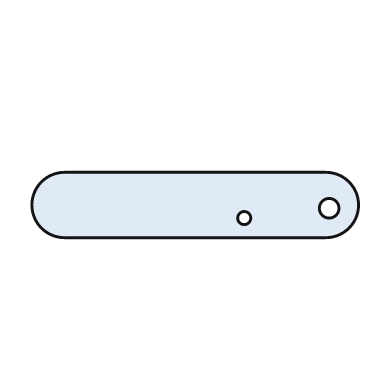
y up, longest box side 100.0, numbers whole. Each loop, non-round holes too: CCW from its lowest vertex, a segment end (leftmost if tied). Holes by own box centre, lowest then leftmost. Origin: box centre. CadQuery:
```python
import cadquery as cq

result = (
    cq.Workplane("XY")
    .moveTo(-40.0, -10.0)
    .lineTo(40.0, -10.0)
    .threePointArc((50.0, 0.0), (40.0, 10.0))
    .lineTo(-40.0, 10.0)
    .threePointArc((-50.0, 0.0), (-40.0, -10.0))
    .close()
    .moveTo(15.0, -4.0)
    .circle(2.0)
    .moveTo(41.0, -1.0)
    .circle(3.0)
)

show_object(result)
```